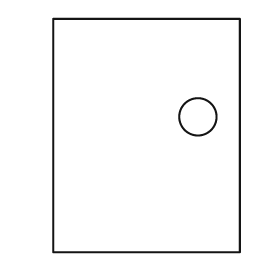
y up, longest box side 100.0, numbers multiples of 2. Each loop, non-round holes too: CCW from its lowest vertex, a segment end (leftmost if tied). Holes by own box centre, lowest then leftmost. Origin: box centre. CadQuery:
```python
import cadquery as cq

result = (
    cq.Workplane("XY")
    .moveTo(-40.0, -50.0)
    .lineTo(40.0, -50.0)
    .lineTo(40.0, 50.0)
    .lineTo(-40.0, 50.0)
    .close()
    .moveTo(22.0, 8.0)
    .circle(8.0)
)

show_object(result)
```